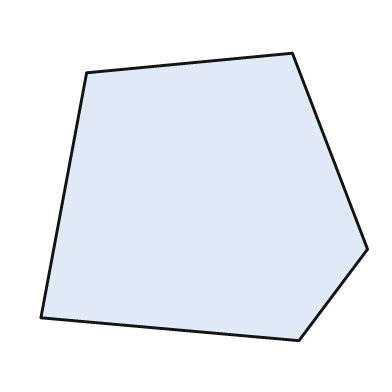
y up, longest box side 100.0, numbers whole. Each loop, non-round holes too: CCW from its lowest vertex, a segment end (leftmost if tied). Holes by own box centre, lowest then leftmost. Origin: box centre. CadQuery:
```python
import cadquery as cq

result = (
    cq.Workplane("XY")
    .moveTo(29.0, -44.0)
    .lineTo(50.0, -16.0)
    .lineTo(27.0, 44.0)
    .lineTo(-36.0, 38.0)
    .lineTo(-50.0, -37.0)
    .close()
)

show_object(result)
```